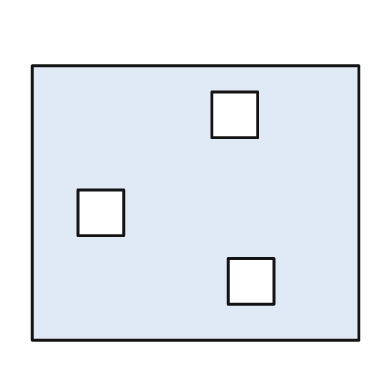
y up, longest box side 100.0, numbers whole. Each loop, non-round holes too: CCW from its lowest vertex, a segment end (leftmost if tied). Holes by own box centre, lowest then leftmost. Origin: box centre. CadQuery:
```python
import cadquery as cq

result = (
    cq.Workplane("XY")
    .moveTo(-50.0, -42.0)
    .lineTo(50.0, -42.0)
    .lineTo(50.0, 42.0)
    .lineTo(-50.0, 42.0)
    .close()
    .moveTo(10.0, -31.0)
    .lineTo(24.0, -31.0)
    .lineTo(24.0, -17.0)
    .lineTo(10.0, -17.0)
    .close()
    .moveTo(-36.0, -10.0)
    .lineTo(-22.0, -10.0)
    .lineTo(-22.0, 4.0)
    .lineTo(-36.0, 4.0)
    .close()
    .moveTo(5.0, 20.0)
    .lineTo(19.0, 20.0)
    .lineTo(19.0, 34.0)
    .lineTo(5.0, 34.0)
    .close()
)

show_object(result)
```